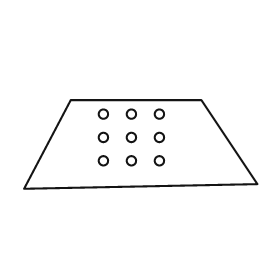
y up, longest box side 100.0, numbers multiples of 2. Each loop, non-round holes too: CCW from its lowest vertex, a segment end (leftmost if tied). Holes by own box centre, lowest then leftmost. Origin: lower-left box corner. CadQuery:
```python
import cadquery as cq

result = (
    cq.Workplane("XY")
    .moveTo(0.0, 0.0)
    .lineTo(100.0, 2.0)
    .lineTo(76.0, 38.0)
    .lineTo(20.0, 38.0)
    .close()
    .moveTo(34.0, 12.0)
    .circle(2.0)
    .moveTo(46.0, 12.0)
    .circle(2.0)
    .moveTo(58.0, 12.0)
    .circle(2.0)
    .moveTo(34.0, 22.0)
    .circle(2.0)
    .moveTo(46.0, 22.0)
    .circle(2.0)
    .moveTo(58.0, 22.0)
    .circle(2.0)
    .moveTo(34.0, 32.0)
    .circle(2.0)
    .moveTo(46.0, 32.0)
    .circle(2.0)
    .moveTo(58.0, 32.0)
    .circle(2.0)
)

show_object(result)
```